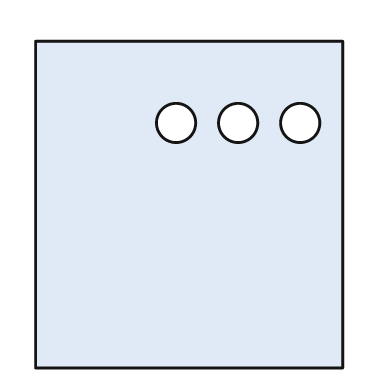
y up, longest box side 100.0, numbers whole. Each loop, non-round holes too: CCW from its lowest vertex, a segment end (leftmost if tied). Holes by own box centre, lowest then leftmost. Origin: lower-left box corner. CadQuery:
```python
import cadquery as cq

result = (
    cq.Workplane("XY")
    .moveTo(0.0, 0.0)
    .lineTo(94.0, 0.0)
    .lineTo(94.0, 100.0)
    .lineTo(0.0, 100.0)
    .close()
    .moveTo(43.0, 75.0)
    .circle(6.0)
    .moveTo(62.0, 75.0)
    .circle(6.0)
    .moveTo(81.0, 75.0)
    .circle(6.0)
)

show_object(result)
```